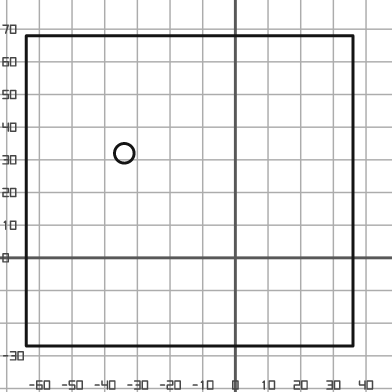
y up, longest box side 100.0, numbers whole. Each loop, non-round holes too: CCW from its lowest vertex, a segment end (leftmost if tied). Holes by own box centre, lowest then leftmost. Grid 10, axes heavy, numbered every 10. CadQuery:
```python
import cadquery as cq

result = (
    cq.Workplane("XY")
    .moveTo(-64.0, -27.0)
    .lineTo(36.0, -27.0)
    .lineTo(36.0, 68.0)
    .lineTo(-64.0, 68.0)
    .close()
    .moveTo(-34.0, 32.0)
    .circle(3.0)
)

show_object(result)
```